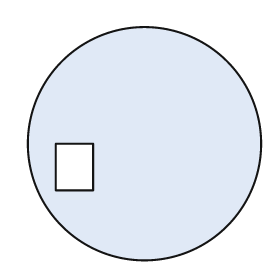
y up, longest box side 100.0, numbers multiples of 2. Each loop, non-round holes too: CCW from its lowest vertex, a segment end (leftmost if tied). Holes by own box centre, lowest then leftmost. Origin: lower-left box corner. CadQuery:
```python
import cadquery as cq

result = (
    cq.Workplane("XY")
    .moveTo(50.0, 50.0)
    .circle(50.0)
    .moveTo(12.0, 30.0)
    .lineTo(28.0, 30.0)
    .lineTo(28.0, 50.0)
    .lineTo(12.0, 50.0)
    .close()
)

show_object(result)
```